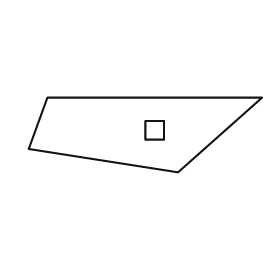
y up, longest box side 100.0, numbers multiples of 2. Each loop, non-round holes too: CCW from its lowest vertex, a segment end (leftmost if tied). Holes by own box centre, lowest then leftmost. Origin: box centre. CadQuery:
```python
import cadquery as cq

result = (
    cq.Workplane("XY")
    .moveTo(14.0, -16.0)
    .lineTo(50.0, 16.0)
    .lineTo(-42.0, 16.0)
    .lineTo(-50.0, -6.0)
    .close()
    .moveTo(0.0, -2.0)
    .lineTo(8.0, -2.0)
    .lineTo(8.0, 6.0)
    .lineTo(0.0, 6.0)
    .close()
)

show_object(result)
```